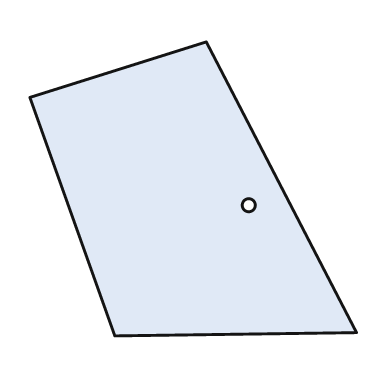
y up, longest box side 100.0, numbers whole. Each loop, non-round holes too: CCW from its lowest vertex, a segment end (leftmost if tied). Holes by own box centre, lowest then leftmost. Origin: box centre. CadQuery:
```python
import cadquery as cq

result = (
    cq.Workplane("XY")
    .moveTo(-24.0, -45.0)
    .lineTo(50.0, -44.0)
    .lineTo(4.0, 45.0)
    .lineTo(-50.0, 28.0)
    .close()
    .moveTo(17.0, -5.0)
    .circle(2.0)
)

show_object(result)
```